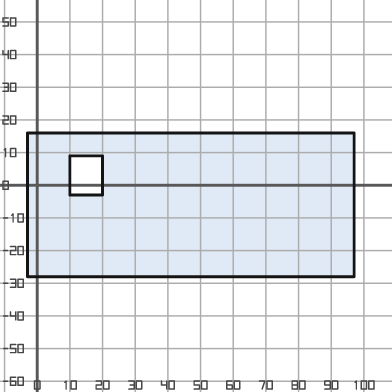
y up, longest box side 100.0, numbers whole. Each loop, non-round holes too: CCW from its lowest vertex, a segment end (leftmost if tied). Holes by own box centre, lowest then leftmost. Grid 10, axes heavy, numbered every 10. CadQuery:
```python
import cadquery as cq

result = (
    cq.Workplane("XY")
    .moveTo(-3.0, -28.0)
    .lineTo(97.0, -28.0)
    .lineTo(97.0, 16.0)
    .lineTo(-3.0, 16.0)
    .close()
    .moveTo(10.0, -3.0)
    .lineTo(20.0, -3.0)
    .lineTo(20.0, 9.0)
    .lineTo(10.0, 9.0)
    .close()
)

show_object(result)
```